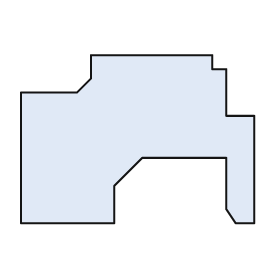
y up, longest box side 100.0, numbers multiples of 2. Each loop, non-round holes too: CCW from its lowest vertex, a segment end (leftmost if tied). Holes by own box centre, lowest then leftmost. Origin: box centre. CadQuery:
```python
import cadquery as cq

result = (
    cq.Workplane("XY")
    .moveTo(-50.0, -36.0)
    .lineTo(-10.0, -36.0)
    .lineTo(-10.0, -20.0)
    .lineTo(2.0, -8.0)
    .lineTo(38.0, -8.0)
    .lineTo(38.0, -30.0)
    .lineTo(42.0, -36.0)
    .lineTo(50.0, -36.0)
    .lineTo(50.0, 10.0)
    .lineTo(38.0, 10.0)
    .lineTo(38.0, 30.0)
    .lineTo(32.0, 30.0)
    .lineTo(32.0, 36.0)
    .lineTo(-20.0, 36.0)
    .lineTo(-20.0, 26.0)
    .lineTo(-26.0, 20.0)
    .lineTo(-50.0, 20.0)
    .close()
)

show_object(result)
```